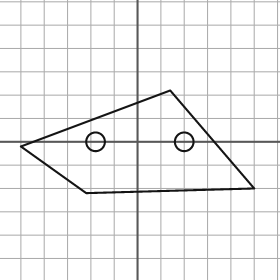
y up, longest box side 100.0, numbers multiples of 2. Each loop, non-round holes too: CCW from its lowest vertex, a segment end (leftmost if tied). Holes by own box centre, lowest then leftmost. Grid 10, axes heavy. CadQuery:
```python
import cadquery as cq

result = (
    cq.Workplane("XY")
    .moveTo(-22.0, -22.0)
    .lineTo(50.0, -20.0)
    .lineTo(14.0, 22.0)
    .lineTo(-50.0, -2.0)
    .close()
    .moveTo(-18.0, 0.0)
    .circle(4.0)
    .moveTo(20.0, 0.0)
    .circle(4.0)
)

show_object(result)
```